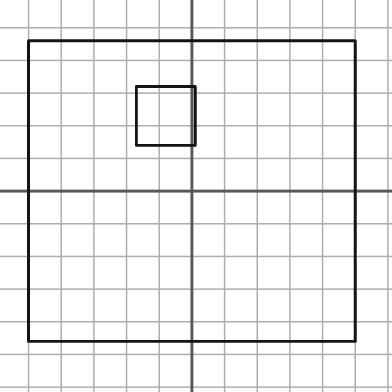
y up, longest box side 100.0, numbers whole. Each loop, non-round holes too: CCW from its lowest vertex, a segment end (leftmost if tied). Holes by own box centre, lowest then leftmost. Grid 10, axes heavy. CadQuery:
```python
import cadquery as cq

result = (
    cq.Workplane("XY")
    .moveTo(-50.0, -46.0)
    .lineTo(50.0, -46.0)
    .lineTo(50.0, 46.0)
    .lineTo(-50.0, 46.0)
    .close()
    .moveTo(-17.0, 14.0)
    .lineTo(1.0, 14.0)
    .lineTo(1.0, 32.0)
    .lineTo(-17.0, 32.0)
    .close()
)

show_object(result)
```